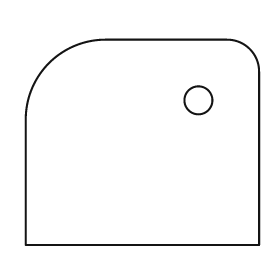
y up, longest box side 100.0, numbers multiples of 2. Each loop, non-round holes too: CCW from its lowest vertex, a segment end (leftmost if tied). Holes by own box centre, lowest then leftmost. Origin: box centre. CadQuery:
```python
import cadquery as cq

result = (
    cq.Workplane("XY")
    .moveTo(-50.0, -44.0)
    .lineTo(50.0, -44.0)
    .lineTo(50.0, 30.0)
    .threePointArc((46.0, 40.0), (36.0, 44.0))
    .lineTo(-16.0, 44.0)
    .threePointArc((-40.0, 34.0), (-50.0, 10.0))
    .close()
    .moveTo(24.0, 18.0)
    .circle(6.0)
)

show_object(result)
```